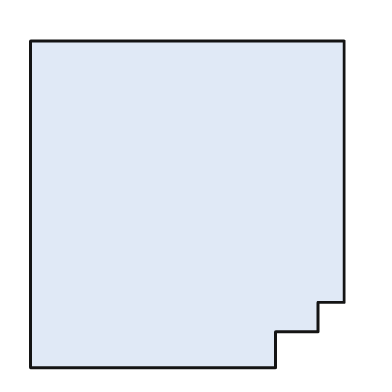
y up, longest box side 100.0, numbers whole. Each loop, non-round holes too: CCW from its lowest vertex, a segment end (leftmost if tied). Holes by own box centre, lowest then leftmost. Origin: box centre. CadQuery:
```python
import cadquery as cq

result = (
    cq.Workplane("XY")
    .moveTo(-48.0, -50.0)
    .lineTo(27.0, -50.0)
    .lineTo(27.0, -39.0)
    .lineTo(40.0, -39.0)
    .lineTo(40.0, -30.0)
    .lineTo(48.0, -30.0)
    .lineTo(48.0, 50.0)
    .lineTo(-48.0, 50.0)
    .close()
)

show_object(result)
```